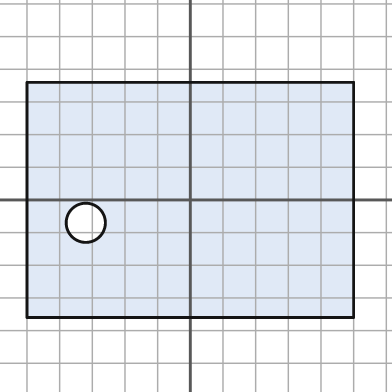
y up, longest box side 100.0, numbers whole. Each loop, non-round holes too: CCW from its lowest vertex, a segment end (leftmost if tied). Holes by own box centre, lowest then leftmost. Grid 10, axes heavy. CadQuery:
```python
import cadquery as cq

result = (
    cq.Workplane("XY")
    .moveTo(-50.0, -36.0)
    .lineTo(50.0, -36.0)
    .lineTo(50.0, 36.0)
    .lineTo(-50.0, 36.0)
    .close()
    .moveTo(-32.0, -7.0)
    .circle(6.0)
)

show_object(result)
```